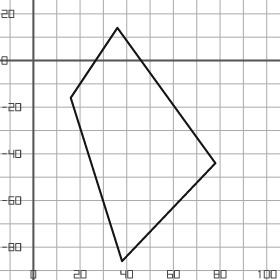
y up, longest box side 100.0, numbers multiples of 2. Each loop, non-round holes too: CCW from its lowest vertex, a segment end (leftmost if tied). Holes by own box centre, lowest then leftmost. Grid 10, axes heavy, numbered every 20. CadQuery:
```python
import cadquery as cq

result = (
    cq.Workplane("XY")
    .moveTo(38.0, -86.0)
    .lineTo(78.0, -44.0)
    .lineTo(36.0, 14.0)
    .lineTo(16.0, -16.0)
    .close()
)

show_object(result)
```